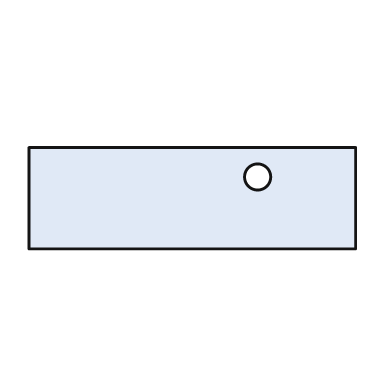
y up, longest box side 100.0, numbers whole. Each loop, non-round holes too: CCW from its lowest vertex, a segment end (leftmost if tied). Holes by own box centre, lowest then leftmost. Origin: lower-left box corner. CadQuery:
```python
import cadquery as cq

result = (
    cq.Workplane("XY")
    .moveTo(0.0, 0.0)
    .lineTo(100.0, 0.0)
    .lineTo(100.0, 31.0)
    .lineTo(0.0, 31.0)
    .close()
    .moveTo(70.0, 22.0)
    .circle(4.0)
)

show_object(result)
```